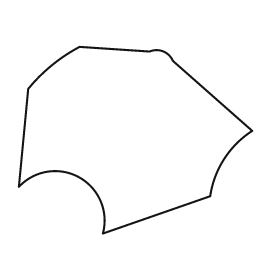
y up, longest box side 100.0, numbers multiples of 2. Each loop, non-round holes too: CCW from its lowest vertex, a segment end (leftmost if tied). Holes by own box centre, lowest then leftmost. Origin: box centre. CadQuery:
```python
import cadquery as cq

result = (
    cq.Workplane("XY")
    .moveTo(-14.0, -40.0)
    .lineTo(32.0, -24.0)
    .threePointArc((38.0, -8.0), (50.0, 4.0))
    .lineTo(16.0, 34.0)
    .threePointArc((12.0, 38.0), (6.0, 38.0))
    .lineTo(-24.0, 40.0)
    .threePointArc((-36.0, 32.0), (-46.0, 22.0))
    .lineTo(-50.0, -20.0)
    .threePointArc((-24.0, -16.0), (-14.0, -40.0))
    .close()
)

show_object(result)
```